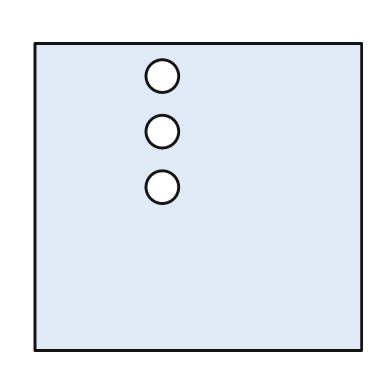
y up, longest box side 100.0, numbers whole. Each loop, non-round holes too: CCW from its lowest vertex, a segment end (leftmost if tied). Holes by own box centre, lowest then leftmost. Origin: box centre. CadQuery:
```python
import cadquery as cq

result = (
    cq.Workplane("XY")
    .moveTo(-50.0, -47.0)
    .lineTo(50.0, -47.0)
    .lineTo(50.0, 47.0)
    .lineTo(-50.0, 47.0)
    .close()
    .moveTo(-11.0, 3.0)
    .circle(5.0)
    .moveTo(-11.0, 20.0)
    .circle(5.0)
    .moveTo(-11.0, 37.0)
    .circle(5.0)
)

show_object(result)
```